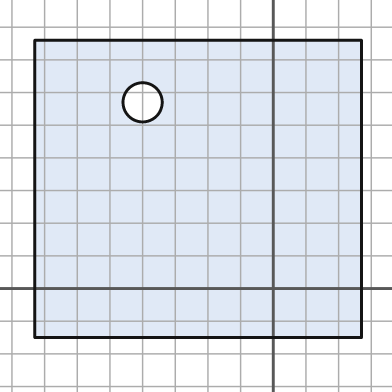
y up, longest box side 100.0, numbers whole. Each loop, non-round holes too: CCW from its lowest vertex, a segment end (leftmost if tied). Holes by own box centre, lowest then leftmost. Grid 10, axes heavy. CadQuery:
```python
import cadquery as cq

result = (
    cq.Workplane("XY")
    .moveTo(-73.0, -15.0)
    .lineTo(27.0, -15.0)
    .lineTo(27.0, 76.0)
    .lineTo(-73.0, 76.0)
    .close()
    .moveTo(-40.0, 57.0)
    .circle(6.0)
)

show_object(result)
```